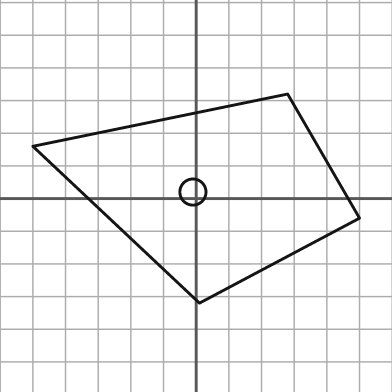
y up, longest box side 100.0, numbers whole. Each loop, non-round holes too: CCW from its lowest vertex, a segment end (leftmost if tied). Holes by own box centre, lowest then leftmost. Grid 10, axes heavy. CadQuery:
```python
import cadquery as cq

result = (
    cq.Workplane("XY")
    .moveTo(1.0, -32.0)
    .lineTo(50.0, -6.0)
    .lineTo(28.0, 32.0)
    .lineTo(-50.0, 16.0)
    .close()
    .moveTo(-1.0, 2.0)
    .circle(4.0)
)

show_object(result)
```